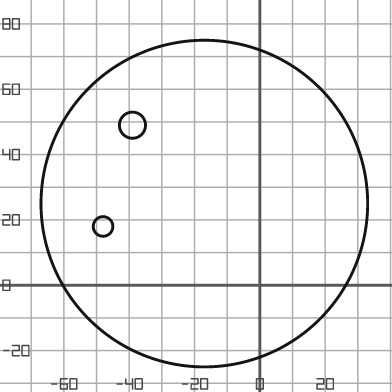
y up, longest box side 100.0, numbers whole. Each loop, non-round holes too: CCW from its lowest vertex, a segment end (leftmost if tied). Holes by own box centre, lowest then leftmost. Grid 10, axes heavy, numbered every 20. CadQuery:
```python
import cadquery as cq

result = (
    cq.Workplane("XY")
    .moveTo(-17.0, 25.0)
    .circle(50.0)
    .moveTo(-48.0, 18.0)
    .circle(3.0)
    .moveTo(-39.0, 49.0)
    .circle(4.0)
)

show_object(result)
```